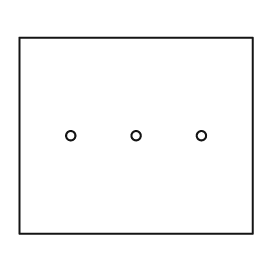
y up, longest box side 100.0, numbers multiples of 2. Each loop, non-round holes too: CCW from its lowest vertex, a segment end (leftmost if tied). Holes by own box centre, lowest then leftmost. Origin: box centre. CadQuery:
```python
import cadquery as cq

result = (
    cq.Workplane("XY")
    .moveTo(-50.0, -42.0)
    .lineTo(50.0, -42.0)
    .lineTo(50.0, 42.0)
    .lineTo(-50.0, 42.0)
    .close()
    .moveTo(-28.0, 0.0)
    .circle(2.0)
    .moveTo(0.0, 0.0)
    .circle(2.0)
    .moveTo(28.0, 0.0)
    .circle(2.0)
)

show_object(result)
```